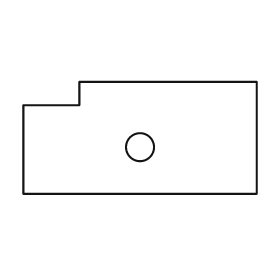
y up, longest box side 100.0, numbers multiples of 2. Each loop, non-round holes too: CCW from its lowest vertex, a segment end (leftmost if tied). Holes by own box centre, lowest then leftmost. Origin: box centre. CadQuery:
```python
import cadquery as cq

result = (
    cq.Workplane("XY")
    .moveTo(-50.0, -24.0)
    .lineTo(50.0, -24.0)
    .lineTo(50.0, 24.0)
    .lineTo(-26.0, 24.0)
    .lineTo(-26.0, 14.0)
    .lineTo(-50.0, 14.0)
    .close()
    .moveTo(0.0, -4.0)
    .circle(6.0)
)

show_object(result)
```